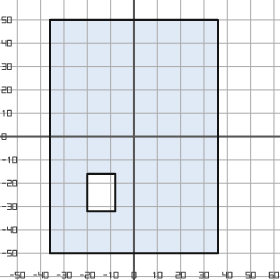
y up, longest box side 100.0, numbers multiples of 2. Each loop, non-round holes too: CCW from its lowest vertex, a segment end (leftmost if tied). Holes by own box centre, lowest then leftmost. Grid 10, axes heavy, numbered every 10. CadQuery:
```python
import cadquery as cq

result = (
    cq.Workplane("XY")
    .moveTo(-36.0, -50.0)
    .lineTo(36.0, -50.0)
    .lineTo(36.0, 50.0)
    .lineTo(-36.0, 50.0)
    .close()
    .moveTo(-20.0, -32.0)
    .lineTo(-8.0, -32.0)
    .lineTo(-8.0, -16.0)
    .lineTo(-20.0, -16.0)
    .close()
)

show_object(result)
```